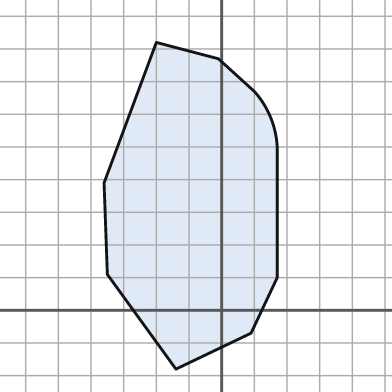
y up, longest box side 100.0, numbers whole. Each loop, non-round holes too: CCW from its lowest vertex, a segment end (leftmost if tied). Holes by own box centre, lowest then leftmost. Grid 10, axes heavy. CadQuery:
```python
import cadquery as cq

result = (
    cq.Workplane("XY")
    .moveTo(-14.0, -18.0)
    .lineTo(9.0, -7.0)
    .lineTo(17.0, 10.0)
    .lineTo(17.0, 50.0)
    .threePointArc((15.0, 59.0), (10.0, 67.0))
    .lineTo(-1.0, 77.0)
    .lineTo(-20.0, 82.0)
    .lineTo(-36.0, 39.0)
    .lineTo(-35.0, 11.0)
    .close()
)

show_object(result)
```